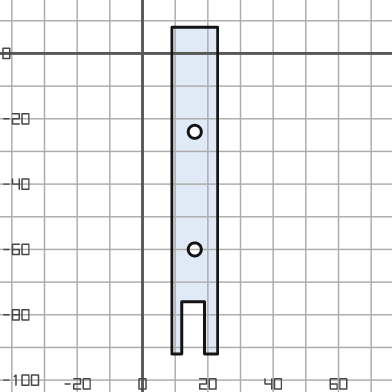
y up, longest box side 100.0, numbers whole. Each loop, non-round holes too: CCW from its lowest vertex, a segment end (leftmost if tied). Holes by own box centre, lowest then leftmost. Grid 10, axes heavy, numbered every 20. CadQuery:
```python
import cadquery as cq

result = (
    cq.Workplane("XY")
    .moveTo(9.0, -92.0)
    .lineTo(12.0, -92.0)
    .lineTo(12.0, -76.0)
    .lineTo(19.0, -76.0)
    .lineTo(19.0, -92.0)
    .lineTo(23.0, -92.0)
    .lineTo(23.0, 8.0)
    .lineTo(9.0, 8.0)
    .close()
    .moveTo(16.0, -60.0)
    .circle(2.0)
    .moveTo(16.0, -24.0)
    .circle(2.0)
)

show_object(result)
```